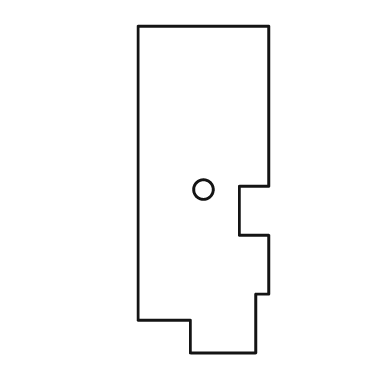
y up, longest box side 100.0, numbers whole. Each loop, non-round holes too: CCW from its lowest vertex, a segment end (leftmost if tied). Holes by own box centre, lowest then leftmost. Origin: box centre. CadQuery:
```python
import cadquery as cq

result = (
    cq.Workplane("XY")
    .moveTo(-4.0, -50.0)
    .lineTo(16.0, -50.0)
    .lineTo(16.0, -32.0)
    .lineTo(20.0, -32.0)
    .lineTo(20.0, -14.0)
    .lineTo(11.0, -14.0)
    .lineTo(11.0, 1.0)
    .lineTo(20.0, 1.0)
    .lineTo(20.0, 50.0)
    .lineTo(-20.0, 50.0)
    .lineTo(-20.0, -40.0)
    .lineTo(-4.0, -40.0)
    .close()
    .moveTo(0.0, 0.0)
    .circle(3.0)
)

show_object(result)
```